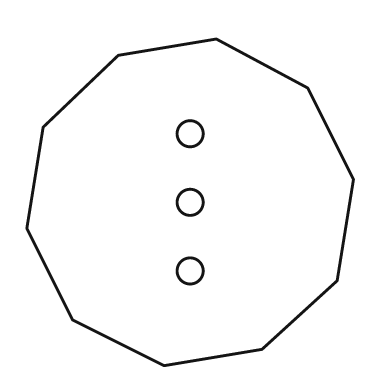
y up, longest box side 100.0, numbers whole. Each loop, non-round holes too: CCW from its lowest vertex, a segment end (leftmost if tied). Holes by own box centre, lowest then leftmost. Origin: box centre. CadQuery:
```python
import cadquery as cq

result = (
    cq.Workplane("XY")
    .moveTo(-8.0, -50.0)
    .lineTo(22.0, -45.0)
    .lineTo(45.0, -24.0)
    .lineTo(50.0, 7.0)
    .lineTo(36.0, 35.0)
    .lineTo(8.0, 50.0)
    .lineTo(-22.0, 45.0)
    .lineTo(-45.0, 23.0)
    .lineTo(-50.0, -8.0)
    .lineTo(-36.0, -36.0)
    .close()
    .moveTo(0.0, -21.0)
    .circle(4.0)
    .moveTo(0.0, 0.0)
    .circle(4.0)
    .moveTo(0.0, 21.0)
    .circle(4.0)
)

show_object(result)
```